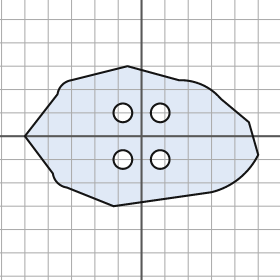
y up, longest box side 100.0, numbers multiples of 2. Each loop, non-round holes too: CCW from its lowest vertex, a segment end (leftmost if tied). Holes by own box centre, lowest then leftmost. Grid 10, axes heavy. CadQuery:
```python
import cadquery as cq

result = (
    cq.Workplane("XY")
    .moveTo(-12.0, -30.0)
    .lineTo(30.0, -24.0)
    .threePointArc((42.0, -18.0), (50.0, -8.0))
    .lineTo(46.0, 6.0)
    .lineTo(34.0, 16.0)
    .threePointArc((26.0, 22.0), (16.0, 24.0))
    .lineTo(-6.0, 30.0)
    .lineTo(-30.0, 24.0)
    .threePointArc((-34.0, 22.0), (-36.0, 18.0))
    .lineTo(-50.0, 0.0)
    .lineTo(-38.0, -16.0)
    .threePointArc((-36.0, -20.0), (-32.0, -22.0))
    .close()
    .moveTo(-8.0, -10.0)
    .circle(4.0)
    .moveTo(8.0, -10.0)
    .circle(4.0)
    .moveTo(-8.0, 10.0)
    .circle(4.0)
    .moveTo(8.0, 10.0)
    .circle(4.0)
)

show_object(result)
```